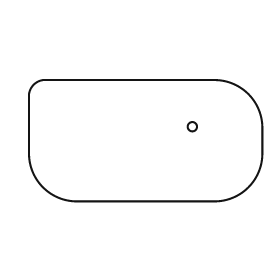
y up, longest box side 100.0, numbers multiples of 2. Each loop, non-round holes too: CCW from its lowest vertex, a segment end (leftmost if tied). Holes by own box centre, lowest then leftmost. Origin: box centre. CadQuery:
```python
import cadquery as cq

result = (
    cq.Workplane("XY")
    .moveTo(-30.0, -26.0)
    .lineTo(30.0, -26.0)
    .threePointArc((44.0, -20.0), (50.0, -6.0))
    .lineTo(50.0, 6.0)
    .threePointArc((44.0, 20.0), (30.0, 26.0))
    .lineTo(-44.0, 26.0)
    .threePointArc((-48.0, 24.0), (-50.0, 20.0))
    .lineTo(-50.0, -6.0)
    .threePointArc((-44.0, -20.0), (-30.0, -26.0))
    .close()
    .moveTo(20.0, 6.0)
    .circle(2.0)
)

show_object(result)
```